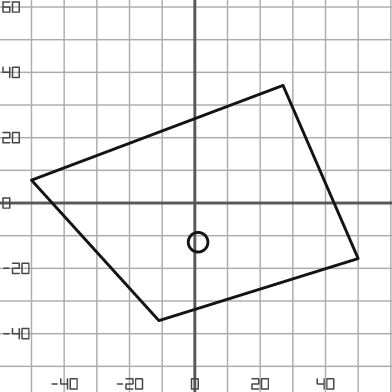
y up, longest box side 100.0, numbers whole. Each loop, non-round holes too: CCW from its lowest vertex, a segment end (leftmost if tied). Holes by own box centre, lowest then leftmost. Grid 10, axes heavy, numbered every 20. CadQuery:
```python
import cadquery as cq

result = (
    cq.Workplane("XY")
    .moveTo(-11.0, -36.0)
    .lineTo(50.0, -17.0)
    .lineTo(27.0, 36.0)
    .lineTo(-50.0, 7.0)
    .close()
    .moveTo(1.0, -12.0)
    .circle(3.0)
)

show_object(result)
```